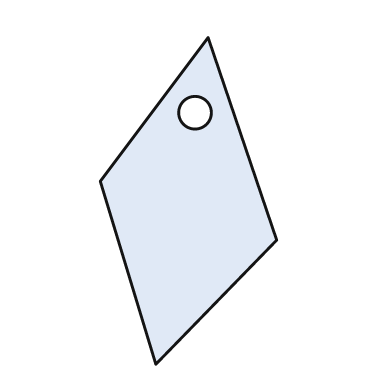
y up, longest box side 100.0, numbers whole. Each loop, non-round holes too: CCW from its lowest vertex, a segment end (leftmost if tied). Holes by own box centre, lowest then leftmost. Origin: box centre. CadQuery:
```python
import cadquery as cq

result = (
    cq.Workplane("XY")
    .moveTo(-10.0, -50.0)
    .lineTo(27.0, -12.0)
    .lineTo(6.0, 50.0)
    .lineTo(-27.0, 6.0)
    .close()
    .moveTo(2.0, 27.0)
    .circle(5.0)
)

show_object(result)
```